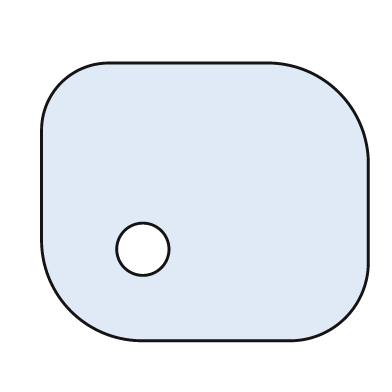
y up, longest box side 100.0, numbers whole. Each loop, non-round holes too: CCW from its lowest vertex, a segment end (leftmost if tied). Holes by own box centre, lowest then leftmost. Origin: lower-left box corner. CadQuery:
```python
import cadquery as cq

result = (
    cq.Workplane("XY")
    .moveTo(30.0, 0.0)
    .lineTo(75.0, 0.0)
    .threePointArc((93.0, 7.0), (100.0, 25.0))
    .lineTo(100.0, 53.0)
    .threePointArc((91.0, 76.0), (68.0, 85.0))
    .lineTo(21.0, 85.0)
    .threePointArc((6.0, 79.0), (0.0, 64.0))
    .lineTo(0.0, 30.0)
    .threePointArc((9.0, 9.0), (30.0, 0.0))
    .close()
    .moveTo(31.0, 28.0)
    .circle(8.0)
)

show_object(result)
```